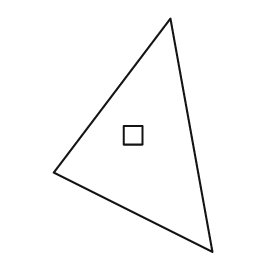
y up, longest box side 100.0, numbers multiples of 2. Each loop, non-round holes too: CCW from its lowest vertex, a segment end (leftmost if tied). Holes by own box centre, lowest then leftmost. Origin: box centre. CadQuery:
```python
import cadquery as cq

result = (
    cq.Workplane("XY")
    .moveTo(34.0, -50.0)
    .lineTo(16.0, 50.0)
    .lineTo(-34.0, -16.0)
    .close()
    .moveTo(-4.0, -4.0)
    .lineTo(4.0, -4.0)
    .lineTo(4.0, 4.0)
    .lineTo(-4.0, 4.0)
    .close()
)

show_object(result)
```